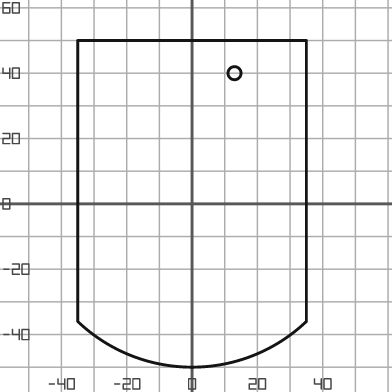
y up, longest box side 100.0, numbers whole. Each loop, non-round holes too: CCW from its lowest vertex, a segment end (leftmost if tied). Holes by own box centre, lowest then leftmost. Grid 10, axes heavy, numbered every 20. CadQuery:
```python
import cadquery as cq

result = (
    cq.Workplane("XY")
    .moveTo(-35.0, -36.0)
    .threePointArc((0.0, -50.0), (35.0, -36.0))
    .lineTo(35.0, 50.0)
    .lineTo(-35.0, 50.0)
    .close()
    .moveTo(13.0, 40.0)
    .circle(2.0)
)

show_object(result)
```